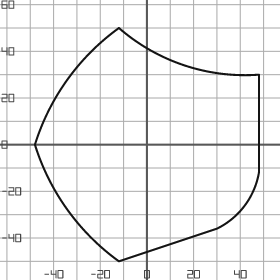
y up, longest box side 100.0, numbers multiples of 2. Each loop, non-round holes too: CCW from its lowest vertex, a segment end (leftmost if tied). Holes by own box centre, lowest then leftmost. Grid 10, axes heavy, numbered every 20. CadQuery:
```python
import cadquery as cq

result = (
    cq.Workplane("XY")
    .moveTo(-12.0, -50.0)
    .lineTo(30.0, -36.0)
    .threePointArc((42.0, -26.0), (48.0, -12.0))
    .lineTo(48.0, 30.0)
    .threePointArc((16.0, 34.0), (-12.0, 50.0))
    .threePointArc((-34.0, 28.0), (-48.0, 0.0))
    .threePointArc((-34.0, -28.0), (-12.0, -50.0))
    .close()
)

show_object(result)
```